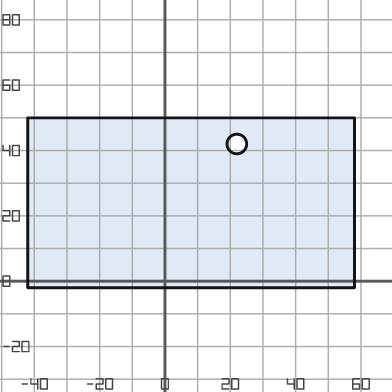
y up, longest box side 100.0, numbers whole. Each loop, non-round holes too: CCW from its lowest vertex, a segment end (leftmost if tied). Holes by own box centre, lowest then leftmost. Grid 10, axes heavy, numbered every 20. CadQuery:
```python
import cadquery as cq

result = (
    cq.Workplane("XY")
    .moveTo(-42.0, -2.0)
    .lineTo(58.0, -2.0)
    .lineTo(58.0, 50.0)
    .lineTo(-42.0, 50.0)
    .close()
    .moveTo(22.0, 42.0)
    .circle(3.0)
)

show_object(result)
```